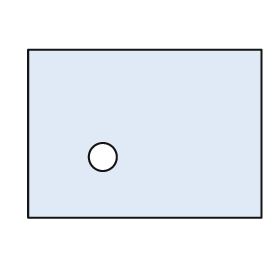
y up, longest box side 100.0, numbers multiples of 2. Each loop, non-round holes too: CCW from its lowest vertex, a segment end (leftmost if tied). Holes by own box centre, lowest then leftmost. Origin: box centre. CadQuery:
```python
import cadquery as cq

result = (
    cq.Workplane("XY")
    .moveTo(-50.0, -36.0)
    .lineTo(50.0, -36.0)
    .lineTo(50.0, 36.0)
    .lineTo(-50.0, 36.0)
    .close()
    .moveTo(-18.0, -10.0)
    .circle(6.0)
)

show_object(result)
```